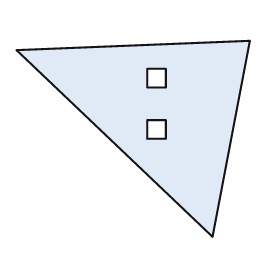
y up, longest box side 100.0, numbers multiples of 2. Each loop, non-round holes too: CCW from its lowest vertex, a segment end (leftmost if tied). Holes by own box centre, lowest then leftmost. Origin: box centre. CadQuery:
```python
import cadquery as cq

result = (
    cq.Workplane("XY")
    .moveTo(34.0, -42.0)
    .lineTo(50.0, 42.0)
    .lineTo(-50.0, 38.0)
    .close()
    .moveTo(6.0, 0.0)
    .lineTo(14.0, 0.0)
    .lineTo(14.0, 8.0)
    .lineTo(6.0, 8.0)
    .close()
    .moveTo(6.0, 22.0)
    .lineTo(14.0, 22.0)
    .lineTo(14.0, 30.0)
    .lineTo(6.0, 30.0)
    .close()
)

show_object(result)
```